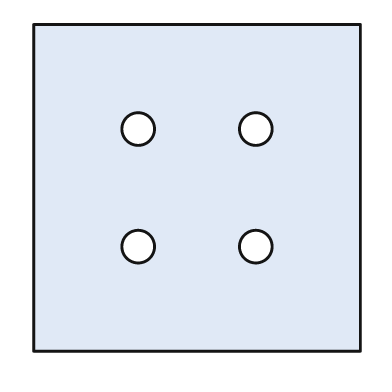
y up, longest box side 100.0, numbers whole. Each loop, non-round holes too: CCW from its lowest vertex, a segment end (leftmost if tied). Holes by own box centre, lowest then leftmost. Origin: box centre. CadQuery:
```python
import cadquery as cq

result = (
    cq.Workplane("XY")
    .moveTo(-50.0, -50.0)
    .lineTo(50.0, -50.0)
    .lineTo(50.0, 50.0)
    .lineTo(-50.0, 50.0)
    .close()
    .moveTo(-18.0, -18.0)
    .circle(5.0)
    .moveTo(18.0, -18.0)
    .circle(5.0)
    .moveTo(-18.0, 18.0)
    .circle(5.0)
    .moveTo(18.0, 18.0)
    .circle(5.0)
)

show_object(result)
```